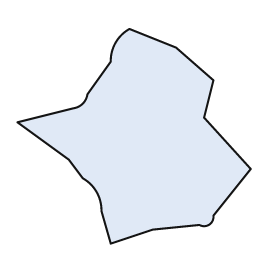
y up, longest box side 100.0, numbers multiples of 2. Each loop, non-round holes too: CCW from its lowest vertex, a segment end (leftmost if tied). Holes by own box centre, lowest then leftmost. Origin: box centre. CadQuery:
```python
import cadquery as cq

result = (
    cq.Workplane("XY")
    .moveTo(-10.0, -46.0)
    .lineTo(8.0, -40.0)
    .lineTo(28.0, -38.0)
    .threePointArc((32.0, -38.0), (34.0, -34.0))
    .lineTo(50.0, -14.0)
    .lineTo(30.0, 8.0)
    .lineTo(34.0, 24.0)
    .lineTo(18.0, 38.0)
    .lineTo(-2.0, 46.0)
    .threePointArc((-8.0, 40.0), (-10.0, 32.0))
    .lineTo(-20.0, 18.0)
    .threePointArc((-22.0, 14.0), (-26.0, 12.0))
    .lineTo(-50.0, 6.0)
    .lineTo(-28.0, -10.0)
    .lineTo(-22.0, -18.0)
    .threePointArc((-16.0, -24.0), (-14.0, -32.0))
    .close()
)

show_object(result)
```